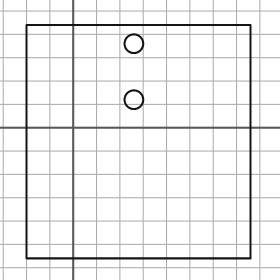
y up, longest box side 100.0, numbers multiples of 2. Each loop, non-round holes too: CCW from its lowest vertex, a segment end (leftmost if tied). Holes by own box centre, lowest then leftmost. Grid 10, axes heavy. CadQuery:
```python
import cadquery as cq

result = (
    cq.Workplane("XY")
    .moveTo(-20.0, -56.0)
    .lineTo(76.0, -56.0)
    .lineTo(76.0, 44.0)
    .lineTo(-20.0, 44.0)
    .close()
    .moveTo(26.0, 12.0)
    .circle(4.0)
    .moveTo(26.0, 36.0)
    .circle(4.0)
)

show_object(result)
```